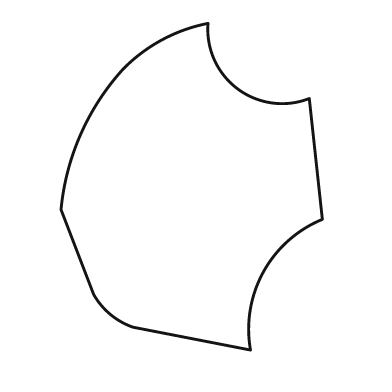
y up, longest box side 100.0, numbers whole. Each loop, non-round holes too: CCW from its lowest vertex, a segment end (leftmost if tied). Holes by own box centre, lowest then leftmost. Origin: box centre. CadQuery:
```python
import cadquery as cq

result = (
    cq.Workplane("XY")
    .moveTo(18.0, -50.0)
    .threePointArc((22.0, -26.0), (40.0, -10.0))
    .lineTo(36.0, 27.0)
    .threePointArc((14.0, 30.0), (5.0, 50.0))
    .threePointArc((-9.0, 45.0), (-21.0, 36.0))
    .threePointArc((-34.0, 16.0), (-40.0, -7.0))
    .lineTo(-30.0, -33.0)
    .threePointArc((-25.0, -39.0), (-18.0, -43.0))
    .close()
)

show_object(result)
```